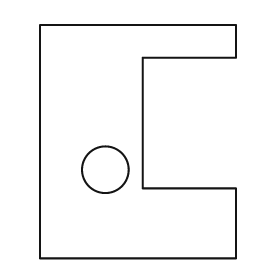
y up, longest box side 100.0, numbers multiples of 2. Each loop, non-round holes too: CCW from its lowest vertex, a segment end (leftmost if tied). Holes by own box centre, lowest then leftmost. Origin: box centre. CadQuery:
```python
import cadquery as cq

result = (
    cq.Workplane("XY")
    .moveTo(-42.0, -50.0)
    .lineTo(42.0, -50.0)
    .lineTo(42.0, -20.0)
    .lineTo(2.0, -20.0)
    .lineTo(2.0, 36.0)
    .lineTo(42.0, 36.0)
    .lineTo(42.0, 50.0)
    .lineTo(-42.0, 50.0)
    .close()
    .moveTo(-14.0, -12.0)
    .circle(10.0)
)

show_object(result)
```